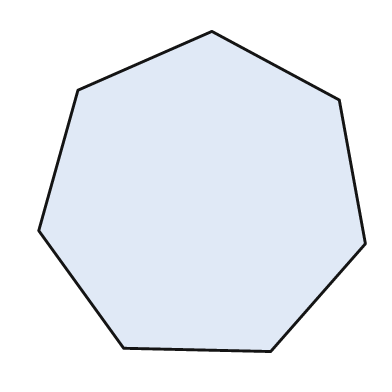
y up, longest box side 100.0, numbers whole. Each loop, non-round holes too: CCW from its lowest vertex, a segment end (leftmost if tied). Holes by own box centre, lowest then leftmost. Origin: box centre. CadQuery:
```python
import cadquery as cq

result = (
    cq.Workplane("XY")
    .moveTo(21.0, -49.0)
    .lineTo(50.0, -16.0)
    .lineTo(42.0, 28.0)
    .lineTo(3.0, 49.0)
    .lineTo(-38.0, 31.0)
    .lineTo(-50.0, -12.0)
    .lineTo(-24.0, -48.0)
    .close()
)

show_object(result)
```